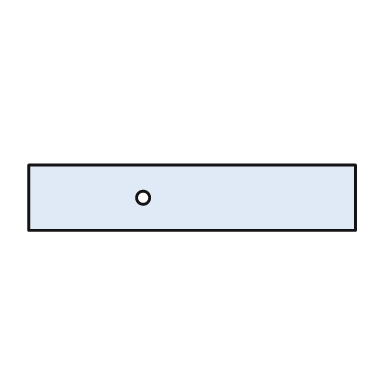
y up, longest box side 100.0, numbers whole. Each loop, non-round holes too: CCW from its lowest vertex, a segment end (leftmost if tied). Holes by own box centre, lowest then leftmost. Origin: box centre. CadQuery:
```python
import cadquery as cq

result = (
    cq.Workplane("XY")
    .moveTo(-50.0, -10.0)
    .lineTo(50.0, -10.0)
    .lineTo(50.0, 10.0)
    .lineTo(-50.0, 10.0)
    .close()
    .moveTo(-15.0, 0.0)
    .circle(2.0)
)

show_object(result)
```